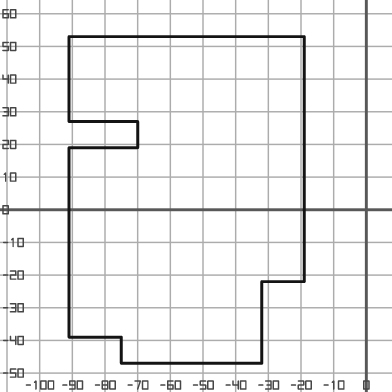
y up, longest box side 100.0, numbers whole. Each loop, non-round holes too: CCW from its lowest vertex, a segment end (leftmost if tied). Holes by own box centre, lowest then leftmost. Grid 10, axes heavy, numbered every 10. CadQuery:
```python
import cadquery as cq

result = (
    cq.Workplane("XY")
    .moveTo(-75.0, -47.0)
    .lineTo(-32.0, -47.0)
    .lineTo(-32.0, -22.0)
    .lineTo(-19.0, -22.0)
    .lineTo(-19.0, 53.0)
    .lineTo(-91.0, 53.0)
    .lineTo(-91.0, 27.0)
    .lineTo(-70.0, 27.0)
    .lineTo(-70.0, 19.0)
    .lineTo(-91.0, 19.0)
    .lineTo(-91.0, -39.0)
    .lineTo(-75.0, -39.0)
    .close()
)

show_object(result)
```